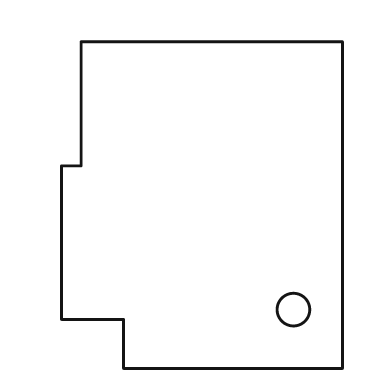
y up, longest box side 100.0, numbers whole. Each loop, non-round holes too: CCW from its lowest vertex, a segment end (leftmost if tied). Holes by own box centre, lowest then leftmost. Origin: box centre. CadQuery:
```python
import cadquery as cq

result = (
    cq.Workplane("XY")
    .moveTo(-24.0, -50.0)
    .lineTo(43.0, -50.0)
    .lineTo(43.0, 50.0)
    .lineTo(-37.0, 50.0)
    .lineTo(-37.0, 12.0)
    .lineTo(-43.0, 12.0)
    .lineTo(-43.0, -35.0)
    .lineTo(-24.0, -35.0)
    .close()
    .moveTo(28.0, -32.0)
    .circle(5.0)
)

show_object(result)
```